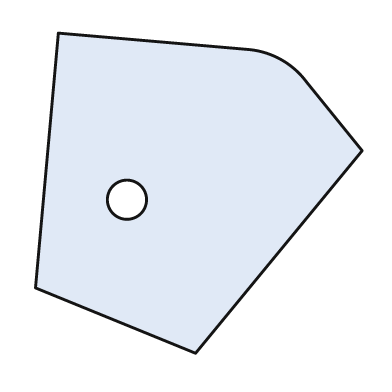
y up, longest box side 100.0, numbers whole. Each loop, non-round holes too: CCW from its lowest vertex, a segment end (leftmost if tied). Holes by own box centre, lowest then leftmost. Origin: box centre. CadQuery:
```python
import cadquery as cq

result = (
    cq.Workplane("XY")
    .moveTo(-1.0, -49.0)
    .lineTo(50.0, 13.0)
    .lineTo(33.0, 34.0)
    .threePointArc((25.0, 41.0), (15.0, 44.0))
    .lineTo(-43.0, 49.0)
    .lineTo(-50.0, -29.0)
    .close()
    .moveTo(-22.0, -2.0)
    .circle(6.0)
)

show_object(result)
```